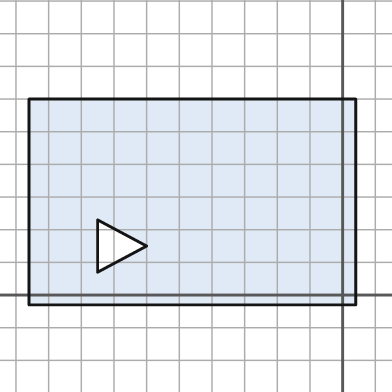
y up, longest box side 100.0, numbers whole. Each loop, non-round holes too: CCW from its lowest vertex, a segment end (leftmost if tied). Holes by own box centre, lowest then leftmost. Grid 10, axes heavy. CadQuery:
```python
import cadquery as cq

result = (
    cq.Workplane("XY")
    .moveTo(-96.0, -3.0)
    .lineTo(4.0, -3.0)
    .lineTo(4.0, 60.0)
    .lineTo(-96.0, 60.0)
    .close()
    .moveTo(-75.0, 7.0)
    .lineTo(-60.0, 15.0)
    .lineTo(-75.0, 23.0)
    .close()
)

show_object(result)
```